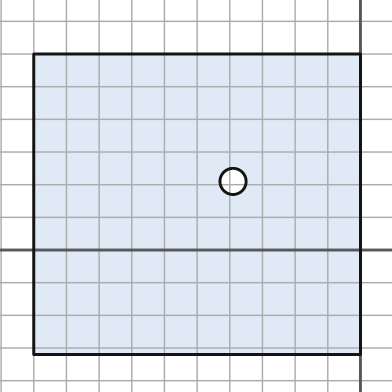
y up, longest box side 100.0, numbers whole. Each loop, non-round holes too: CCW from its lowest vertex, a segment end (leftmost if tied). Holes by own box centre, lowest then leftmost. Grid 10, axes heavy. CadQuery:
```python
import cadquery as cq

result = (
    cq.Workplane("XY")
    .moveTo(-100.0, -32.0)
    .lineTo(0.0, -32.0)
    .lineTo(0.0, 60.0)
    .lineTo(-100.0, 60.0)
    .close()
    .moveTo(-39.0, 21.0)
    .circle(4.0)
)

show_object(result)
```